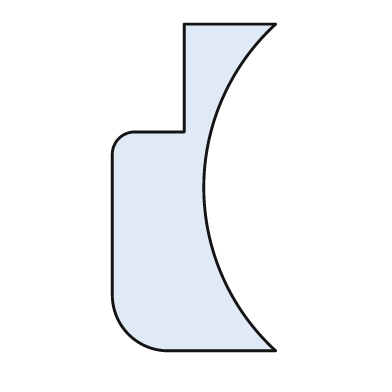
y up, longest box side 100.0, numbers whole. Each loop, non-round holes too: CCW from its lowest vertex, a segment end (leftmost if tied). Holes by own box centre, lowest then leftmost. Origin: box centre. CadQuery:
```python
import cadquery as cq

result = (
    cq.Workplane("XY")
    .moveTo(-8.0, -50.0)
    .lineTo(25.0, -50.0)
    .threePointArc((3.0, 0.0), (25.0, 50.0))
    .lineTo(-3.0, 50.0)
    .lineTo(-3.0, 17.0)
    .lineTo(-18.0, 17.0)
    .threePointArc((-23.0, 15.0), (-25.0, 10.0))
    .lineTo(-25.0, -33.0)
    .threePointArc((-20.0, -45.0), (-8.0, -50.0))
    .close()
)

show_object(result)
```